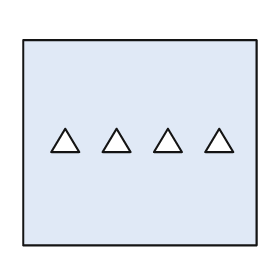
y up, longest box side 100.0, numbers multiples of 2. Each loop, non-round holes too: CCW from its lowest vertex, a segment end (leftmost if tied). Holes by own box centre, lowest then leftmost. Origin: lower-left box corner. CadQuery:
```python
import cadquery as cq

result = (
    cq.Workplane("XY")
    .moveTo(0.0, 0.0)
    .lineTo(100.0, 0.0)
    .lineTo(100.0, 88.0)
    .lineTo(0.0, 88.0)
    .close()
    .moveTo(12.0, 40.0)
    .lineTo(24.0, 40.0)
    .lineTo(18.0, 50.0)
    .close()
    .moveTo(34.0, 40.0)
    .lineTo(46.0, 40.0)
    .lineTo(40.0, 50.0)
    .close()
    .moveTo(56.0, 40.0)
    .lineTo(68.0, 40.0)
    .lineTo(62.0, 50.0)
    .close()
    .moveTo(78.0, 40.0)
    .lineTo(90.0, 40.0)
    .lineTo(84.0, 50.0)
    .close()
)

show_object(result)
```